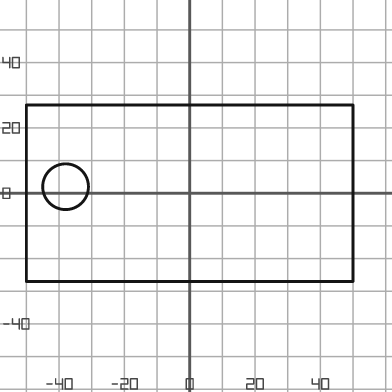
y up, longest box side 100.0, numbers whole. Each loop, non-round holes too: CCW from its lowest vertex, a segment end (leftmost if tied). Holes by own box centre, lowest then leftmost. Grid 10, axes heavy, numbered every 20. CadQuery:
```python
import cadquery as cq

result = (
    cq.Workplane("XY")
    .moveTo(-50.0, -27.0)
    .lineTo(50.0, -27.0)
    .lineTo(50.0, 27.0)
    .lineTo(-50.0, 27.0)
    .close()
    .moveTo(-38.0, 2.0)
    .circle(7.0)
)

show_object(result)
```